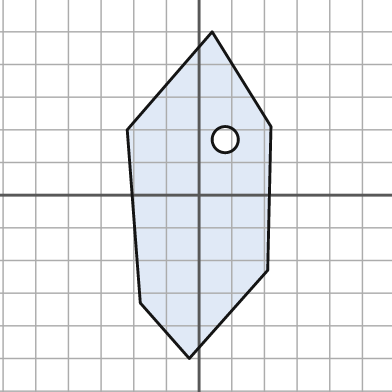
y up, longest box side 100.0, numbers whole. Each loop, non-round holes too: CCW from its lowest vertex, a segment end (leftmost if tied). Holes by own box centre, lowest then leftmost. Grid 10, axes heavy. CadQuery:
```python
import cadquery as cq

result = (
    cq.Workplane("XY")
    .moveTo(-3.0, -50.0)
    .lineTo(21.0, -23.0)
    .lineTo(22.0, 21.0)
    .lineTo(4.0, 50.0)
    .lineTo(-22.0, 20.0)
    .lineTo(-18.0, -33.0)
    .close()
    .moveTo(8.0, 17.0)
    .circle(4.0)
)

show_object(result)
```